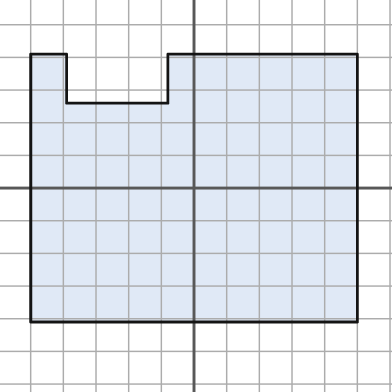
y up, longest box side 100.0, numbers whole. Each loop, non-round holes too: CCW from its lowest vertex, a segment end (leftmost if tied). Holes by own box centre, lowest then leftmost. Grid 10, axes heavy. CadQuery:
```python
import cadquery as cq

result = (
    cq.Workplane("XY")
    .moveTo(-50.0, -41.0)
    .lineTo(50.0, -41.0)
    .lineTo(50.0, 41.0)
    .lineTo(-8.0, 41.0)
    .lineTo(-8.0, 26.0)
    .lineTo(-39.0, 26.0)
    .lineTo(-39.0, 41.0)
    .lineTo(-50.0, 41.0)
    .close()
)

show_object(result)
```